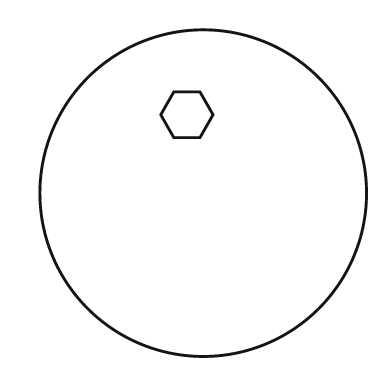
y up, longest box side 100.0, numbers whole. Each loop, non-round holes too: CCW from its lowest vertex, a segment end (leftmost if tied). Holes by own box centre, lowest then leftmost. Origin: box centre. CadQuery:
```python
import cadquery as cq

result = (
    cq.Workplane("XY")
    .moveTo(0.0, 0.0)
    .circle(50.0)
    .moveTo(-9.0, 17.0)
    .lineTo(-1.0, 17.0)
    .lineTo(3.0, 24.0)
    .lineTo(-1.0, 31.0)
    .lineTo(-9.0, 31.0)
    .lineTo(-13.0, 24.0)
    .close()
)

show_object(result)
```